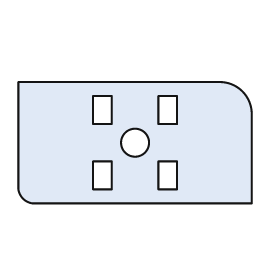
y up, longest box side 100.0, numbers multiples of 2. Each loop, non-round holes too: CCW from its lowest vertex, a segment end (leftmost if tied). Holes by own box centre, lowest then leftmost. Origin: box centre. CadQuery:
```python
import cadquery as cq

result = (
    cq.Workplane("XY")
    .moveTo(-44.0, -26.0)
    .lineTo(50.0, -26.0)
    .lineTo(50.0, 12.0)
    .threePointArc((46.0, 22.0), (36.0, 26.0))
    .lineTo(-50.0, 26.0)
    .lineTo(-50.0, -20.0)
    .threePointArc((-48.0, -24.0), (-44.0, -26.0))
    .close()
    .moveTo(-18.0, -20.0)
    .lineTo(-10.0, -20.0)
    .lineTo(-10.0, -8.0)
    .lineTo(-18.0, -8.0)
    .close()
    .moveTo(10.0, -20.0)
    .lineTo(18.0, -20.0)
    .lineTo(18.0, -8.0)
    .lineTo(10.0, -8.0)
    .close()
    .moveTo(0.0, 0.0)
    .circle(6.0)
    .moveTo(-18.0, 8.0)
    .lineTo(-10.0, 8.0)
    .lineTo(-10.0, 20.0)
    .lineTo(-18.0, 20.0)
    .close()
    .moveTo(10.0, 8.0)
    .lineTo(18.0, 8.0)
    .lineTo(18.0, 20.0)
    .lineTo(10.0, 20.0)
    .close()
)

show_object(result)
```